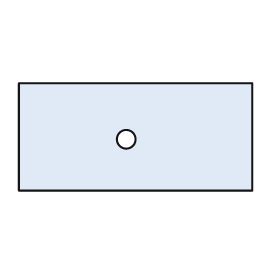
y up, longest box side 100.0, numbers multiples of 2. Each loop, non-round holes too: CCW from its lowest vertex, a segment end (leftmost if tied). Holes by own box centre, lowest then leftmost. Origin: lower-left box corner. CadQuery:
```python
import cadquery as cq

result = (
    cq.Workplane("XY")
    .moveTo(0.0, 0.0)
    .lineTo(100.0, 0.0)
    .lineTo(100.0, 46.0)
    .lineTo(0.0, 46.0)
    .close()
    .moveTo(46.0, 22.0)
    .circle(4.0)
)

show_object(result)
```